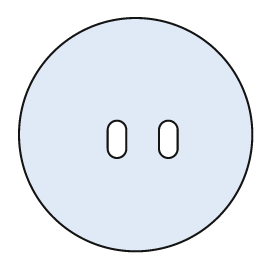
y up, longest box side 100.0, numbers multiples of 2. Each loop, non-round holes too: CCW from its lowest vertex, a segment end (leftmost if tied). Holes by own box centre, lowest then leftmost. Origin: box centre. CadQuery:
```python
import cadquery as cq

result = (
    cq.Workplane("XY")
    .moveTo(0.0, 0.0)
    .circle(50.0)
    .moveTo(-12.0, -6.0)
    .threePointArc((-8.0, -10.0), (-4.0, -6.0))
    .lineTo(-4.0, 2.0)
    .threePointArc((-8.0, 6.0), (-12.0, 2.0))
    .close()
    .moveTo(10.0, -6.0)
    .threePointArc((14.0, -10.0), (18.0, -6.0))
    .lineTo(18.0, 2.0)
    .threePointArc((14.0, 6.0), (10.0, 2.0))
    .close()
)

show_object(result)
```